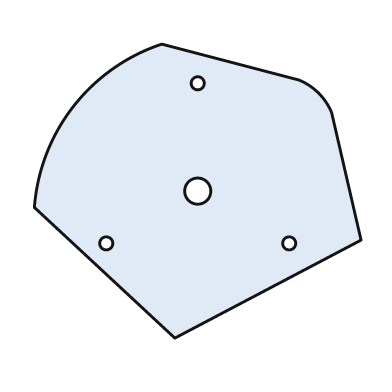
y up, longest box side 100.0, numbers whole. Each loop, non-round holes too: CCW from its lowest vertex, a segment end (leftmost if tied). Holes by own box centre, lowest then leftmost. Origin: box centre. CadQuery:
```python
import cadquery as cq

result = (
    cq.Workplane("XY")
    .moveTo(-7.0, -45.0)
    .lineTo(50.0, -15.0)
    .lineTo(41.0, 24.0)
    .threePointArc((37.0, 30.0), (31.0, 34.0))
    .lineTo(-11.0, 45.0)
    .threePointArc((-38.0, 26.0), (-50.0, -5.0))
    .close()
    .moveTo(-28.0, -16.0)
    .circle(2.0)
    .moveTo(28.0, -16.0)
    .circle(2.0)
    .moveTo(0.0, 0.0)
    .circle(4.0)
    .moveTo(0.0, 33.0)
    .circle(2.0)
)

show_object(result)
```